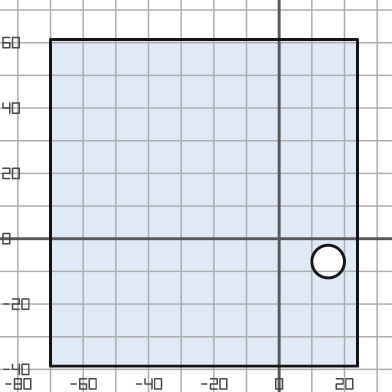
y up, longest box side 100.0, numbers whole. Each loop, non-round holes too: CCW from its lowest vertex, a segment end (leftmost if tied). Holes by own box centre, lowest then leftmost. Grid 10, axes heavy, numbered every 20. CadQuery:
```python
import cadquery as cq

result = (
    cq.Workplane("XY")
    .moveTo(-70.0, -39.0)
    .lineTo(24.0, -39.0)
    .lineTo(24.0, 61.0)
    .lineTo(-70.0, 61.0)
    .close()
    .moveTo(15.0, -7.0)
    .circle(5.0)
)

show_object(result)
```